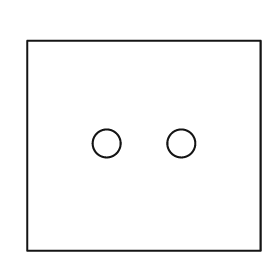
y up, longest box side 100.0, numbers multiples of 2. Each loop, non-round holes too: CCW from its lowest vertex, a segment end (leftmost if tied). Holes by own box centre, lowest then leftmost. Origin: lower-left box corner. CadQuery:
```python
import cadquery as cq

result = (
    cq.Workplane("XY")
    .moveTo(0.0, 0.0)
    .lineTo(100.0, 0.0)
    .lineTo(100.0, 90.0)
    .lineTo(0.0, 90.0)
    .close()
    .moveTo(34.0, 46.0)
    .circle(6.0)
    .moveTo(66.0, 46.0)
    .circle(6.0)
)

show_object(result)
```